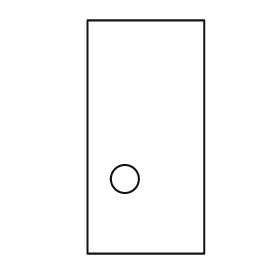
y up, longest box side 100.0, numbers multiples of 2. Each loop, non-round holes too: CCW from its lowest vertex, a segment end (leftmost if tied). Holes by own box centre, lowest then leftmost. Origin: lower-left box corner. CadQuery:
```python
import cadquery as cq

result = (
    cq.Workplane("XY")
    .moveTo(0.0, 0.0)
    .lineTo(50.0, 0.0)
    .lineTo(50.0, 100.0)
    .lineTo(0.0, 100.0)
    .close()
    .moveTo(16.0, 32.0)
    .circle(6.0)
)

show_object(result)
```